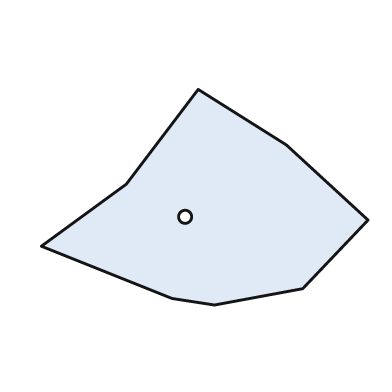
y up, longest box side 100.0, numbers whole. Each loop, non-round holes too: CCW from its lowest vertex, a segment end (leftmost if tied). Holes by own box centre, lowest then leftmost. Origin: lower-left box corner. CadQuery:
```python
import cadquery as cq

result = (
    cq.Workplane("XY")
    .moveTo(53.0, 0.0)
    .lineTo(80.0, 5.0)
    .lineTo(100.0, 26.0)
    .lineTo(75.0, 49.0)
    .lineTo(48.0, 66.0)
    .lineTo(26.0, 37.0)
    .lineTo(0.0, 18.0)
    .lineTo(40.0, 2.0)
    .close()
    .moveTo(44.0, 27.0)
    .circle(2.0)
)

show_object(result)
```